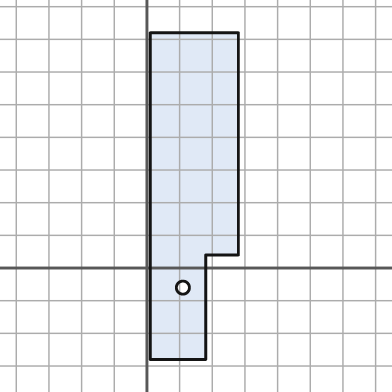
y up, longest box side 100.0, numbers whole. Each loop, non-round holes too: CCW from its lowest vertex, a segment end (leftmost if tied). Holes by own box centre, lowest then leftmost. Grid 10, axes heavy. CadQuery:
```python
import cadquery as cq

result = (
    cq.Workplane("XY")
    .moveTo(1.0, -28.0)
    .lineTo(18.0, -28.0)
    .lineTo(18.0, 4.0)
    .lineTo(28.0, 4.0)
    .lineTo(28.0, 72.0)
    .lineTo(1.0, 72.0)
    .close()
    .moveTo(11.0, -6.0)
    .circle(2.0)
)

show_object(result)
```